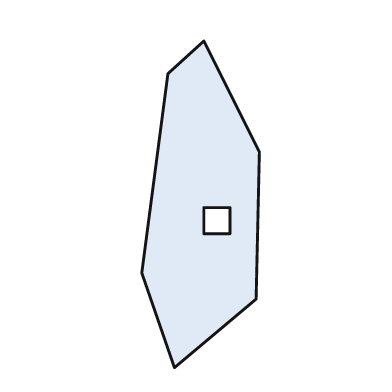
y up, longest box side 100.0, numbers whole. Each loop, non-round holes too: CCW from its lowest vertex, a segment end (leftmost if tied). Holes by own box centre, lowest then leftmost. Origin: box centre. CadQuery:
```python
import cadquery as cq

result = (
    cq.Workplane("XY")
    .moveTo(-8.0, -50.0)
    .lineTo(17.0, -29.0)
    .lineTo(18.0, 16.0)
    .lineTo(1.0, 50.0)
    .lineTo(-10.0, 40.0)
    .lineTo(-18.0, -21.0)
    .close()
    .moveTo(1.0, -9.0)
    .lineTo(9.0, -9.0)
    .lineTo(9.0, -1.0)
    .lineTo(1.0, -1.0)
    .close()
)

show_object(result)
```